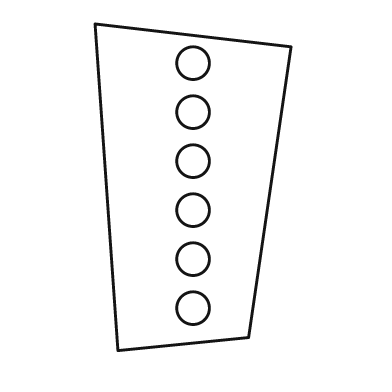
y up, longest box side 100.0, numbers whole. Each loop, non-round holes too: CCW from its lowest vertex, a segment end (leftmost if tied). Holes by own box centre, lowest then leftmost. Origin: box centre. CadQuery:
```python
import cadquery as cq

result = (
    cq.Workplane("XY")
    .moveTo(-23.0, -50.0)
    .lineTo(17.0, -46.0)
    .lineTo(30.0, 43.0)
    .lineTo(-30.0, 50.0)
    .close()
    .moveTo(0.0, -37.0)
    .circle(5.0)
    .moveTo(0.0, -22.0)
    .circle(5.0)
    .moveTo(0.0, -7.0)
    .circle(5.0)
    .moveTo(0.0, 8.0)
    .circle(5.0)
    .moveTo(0.0, 23.0)
    .circle(5.0)
    .moveTo(0.0, 38.0)
    .circle(5.0)
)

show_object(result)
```